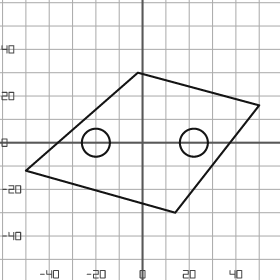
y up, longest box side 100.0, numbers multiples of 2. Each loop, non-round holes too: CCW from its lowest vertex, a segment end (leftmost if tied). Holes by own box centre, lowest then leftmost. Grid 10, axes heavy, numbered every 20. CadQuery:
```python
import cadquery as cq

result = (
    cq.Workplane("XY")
    .moveTo(14.0, -30.0)
    .lineTo(50.0, 16.0)
    .lineTo(-2.0, 30.0)
    .lineTo(-50.0, -12.0)
    .close()
    .moveTo(-20.0, 0.0)
    .circle(6.0)
    .moveTo(22.0, 0.0)
    .circle(6.0)
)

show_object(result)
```